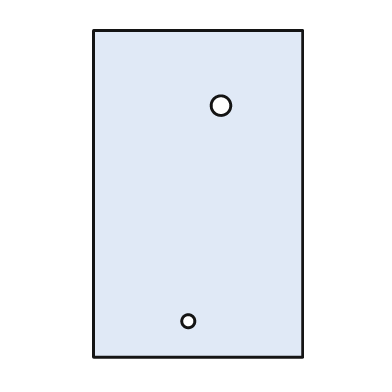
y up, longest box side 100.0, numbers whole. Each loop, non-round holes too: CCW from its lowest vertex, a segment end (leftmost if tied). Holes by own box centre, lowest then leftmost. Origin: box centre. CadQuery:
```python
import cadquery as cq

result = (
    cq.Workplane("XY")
    .moveTo(-32.0, -50.0)
    .lineTo(32.0, -50.0)
    .lineTo(32.0, 50.0)
    .lineTo(-32.0, 50.0)
    .close()
    .moveTo(-3.0, -39.0)
    .circle(2.0)
    .moveTo(7.0, 27.0)
    .circle(3.0)
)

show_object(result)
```